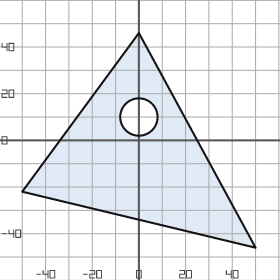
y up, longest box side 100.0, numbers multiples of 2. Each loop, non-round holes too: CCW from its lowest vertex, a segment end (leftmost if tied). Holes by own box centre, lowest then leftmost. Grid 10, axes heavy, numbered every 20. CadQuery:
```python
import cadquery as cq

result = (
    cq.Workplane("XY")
    .moveTo(50.0, -46.0)
    .lineTo(0.0, 46.0)
    .lineTo(-50.0, -22.0)
    .close()
    .moveTo(0.0, 10.0)
    .circle(8.0)
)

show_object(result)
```